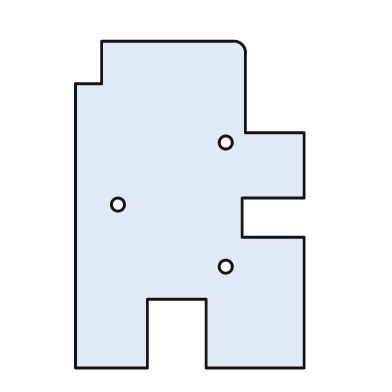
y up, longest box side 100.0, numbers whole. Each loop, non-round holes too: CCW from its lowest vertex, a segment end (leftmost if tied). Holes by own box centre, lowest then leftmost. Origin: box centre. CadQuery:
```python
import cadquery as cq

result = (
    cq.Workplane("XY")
    .moveTo(-35.0, -50.0)
    .lineTo(-13.0, -50.0)
    .lineTo(-13.0, -29.0)
    .lineTo(5.0, -29.0)
    .lineTo(5.0, -50.0)
    .lineTo(35.0, -50.0)
    .lineTo(35.0, -10.0)
    .lineTo(16.0, -10.0)
    .lineTo(16.0, 2.0)
    .lineTo(35.0, 2.0)
    .lineTo(35.0, 22.0)
    .lineTo(17.0, 22.0)
    .lineTo(17.0, 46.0)
    .threePointArc((16.0, 49.0), (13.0, 50.0))
    .lineTo(-27.0, 50.0)
    .lineTo(-27.0, 37.0)
    .lineTo(-35.0, 37.0)
    .close()
    .moveTo(11.0, -19.0)
    .circle(2.0)
    .moveTo(-22.0, 0.0)
    .circle(2.0)
    .moveTo(11.0, 19.0)
    .circle(2.0)
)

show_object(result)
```